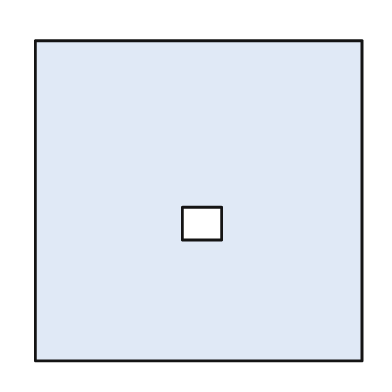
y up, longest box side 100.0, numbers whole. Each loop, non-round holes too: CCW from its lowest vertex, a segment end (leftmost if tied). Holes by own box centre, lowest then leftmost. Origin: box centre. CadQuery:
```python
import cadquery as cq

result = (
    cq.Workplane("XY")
    .moveTo(-50.0, -49.0)
    .lineTo(50.0, -49.0)
    .lineTo(50.0, 49.0)
    .lineTo(-50.0, 49.0)
    .close()
    .moveTo(-5.0, -12.0)
    .lineTo(7.0, -12.0)
    .lineTo(7.0, -2.0)
    .lineTo(-5.0, -2.0)
    .close()
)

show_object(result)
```